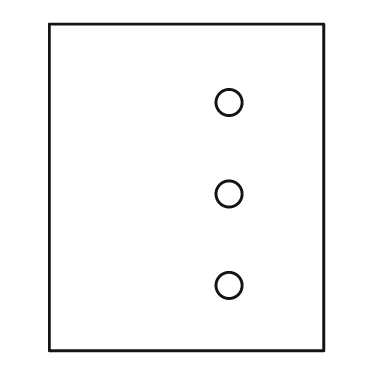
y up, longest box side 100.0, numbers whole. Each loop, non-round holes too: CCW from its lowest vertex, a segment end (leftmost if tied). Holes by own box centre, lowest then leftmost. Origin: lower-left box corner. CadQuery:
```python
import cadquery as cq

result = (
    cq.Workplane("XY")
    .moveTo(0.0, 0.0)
    .lineTo(84.0, 0.0)
    .lineTo(84.0, 100.0)
    .lineTo(0.0, 100.0)
    .close()
    .moveTo(55.0, 20.0)
    .circle(4.0)
    .moveTo(55.0, 48.0)
    .circle(4.0)
    .moveTo(55.0, 76.0)
    .circle(4.0)
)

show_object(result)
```